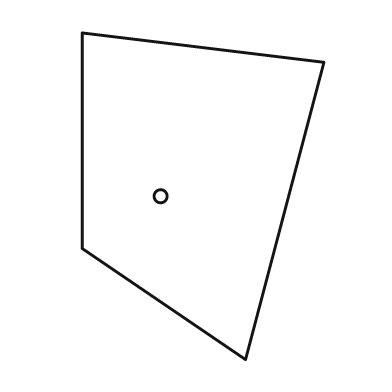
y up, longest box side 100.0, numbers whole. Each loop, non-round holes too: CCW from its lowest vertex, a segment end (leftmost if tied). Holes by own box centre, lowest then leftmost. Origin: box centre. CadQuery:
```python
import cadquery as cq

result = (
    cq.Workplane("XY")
    .moveTo(13.0, -50.0)
    .lineTo(37.0, 41.0)
    .lineTo(-37.0, 50.0)
    .lineTo(-37.0, -16.0)
    .close()
    .moveTo(-13.0, 0.0)
    .circle(2.0)
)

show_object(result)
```